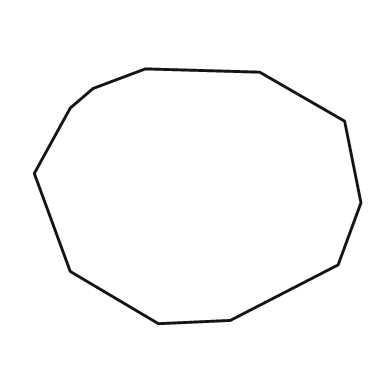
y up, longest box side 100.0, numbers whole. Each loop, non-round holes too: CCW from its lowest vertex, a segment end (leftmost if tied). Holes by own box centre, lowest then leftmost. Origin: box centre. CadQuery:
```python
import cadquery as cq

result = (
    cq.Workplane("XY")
    .moveTo(-12.0, -39.0)
    .lineTo(10.0, -38.0)
    .lineTo(43.0, -21.0)
    .lineTo(50.0, -2.0)
    .lineTo(45.0, 23.0)
    .lineTo(19.0, 38.0)
    .lineTo(-16.0, 39.0)
    .lineTo(-32.0, 33.0)
    .lineTo(-39.0, 27.0)
    .lineTo(-50.0, 7.0)
    .lineTo(-39.0, -23.0)
    .close()
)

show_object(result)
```